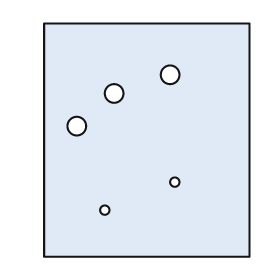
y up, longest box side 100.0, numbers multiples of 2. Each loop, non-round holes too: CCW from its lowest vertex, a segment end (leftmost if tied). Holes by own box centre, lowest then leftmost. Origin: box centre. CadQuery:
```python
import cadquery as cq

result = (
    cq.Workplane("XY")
    .moveTo(-44.0, -50.0)
    .lineTo(44.0, -50.0)
    .lineTo(44.0, 50.0)
    .lineTo(-44.0, 50.0)
    .close()
    .moveTo(-18.0, -30.0)
    .circle(2.0)
    .moveTo(12.0, -18.0)
    .circle(2.0)
    .moveTo(-30.0, 6.0)
    .circle(4.0)
    .moveTo(-14.0, 20.0)
    .circle(4.0)
    .moveTo(10.0, 28.0)
    .circle(4.0)
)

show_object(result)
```